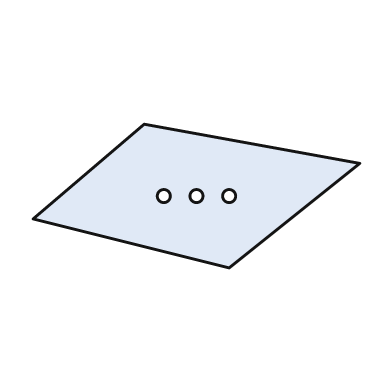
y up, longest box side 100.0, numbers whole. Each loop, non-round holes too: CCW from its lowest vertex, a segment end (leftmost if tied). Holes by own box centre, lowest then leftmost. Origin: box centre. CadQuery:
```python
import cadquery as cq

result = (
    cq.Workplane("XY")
    .moveTo(10.0, -22.0)
    .lineTo(50.0, 10.0)
    .lineTo(-16.0, 22.0)
    .lineTo(-50.0, -7.0)
    .close()
    .moveTo(-10.0, 0.0)
    .circle(2.0)
    .moveTo(0.0, 0.0)
    .circle(2.0)
    .moveTo(10.0, 0.0)
    .circle(2.0)
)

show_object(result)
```